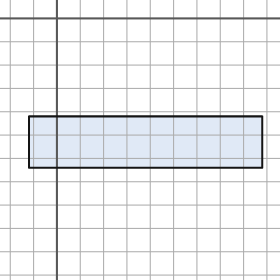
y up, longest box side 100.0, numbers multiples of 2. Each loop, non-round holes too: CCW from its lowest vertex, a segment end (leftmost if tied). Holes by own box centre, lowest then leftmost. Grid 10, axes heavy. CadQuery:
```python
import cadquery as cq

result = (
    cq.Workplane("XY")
    .moveTo(-12.0, -64.0)
    .lineTo(88.0, -64.0)
    .lineTo(88.0, -42.0)
    .lineTo(-12.0, -42.0)
    .close()
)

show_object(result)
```